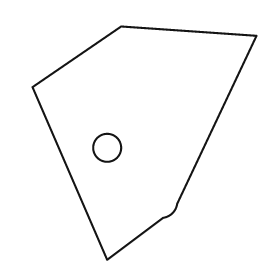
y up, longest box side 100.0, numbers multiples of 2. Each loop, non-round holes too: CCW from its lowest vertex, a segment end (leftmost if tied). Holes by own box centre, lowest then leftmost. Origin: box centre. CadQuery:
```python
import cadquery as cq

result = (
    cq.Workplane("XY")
    .moveTo(-16.0, -50.0)
    .lineTo(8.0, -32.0)
    .threePointArc((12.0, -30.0), (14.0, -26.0))
    .lineTo(48.0, 46.0)
    .lineTo(-10.0, 50.0)
    .lineTo(-48.0, 24.0)
    .close()
    .moveTo(-16.0, -2.0)
    .circle(6.0)
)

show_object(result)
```